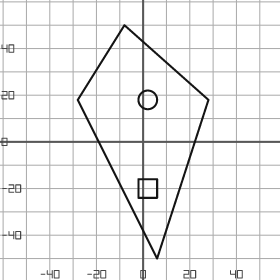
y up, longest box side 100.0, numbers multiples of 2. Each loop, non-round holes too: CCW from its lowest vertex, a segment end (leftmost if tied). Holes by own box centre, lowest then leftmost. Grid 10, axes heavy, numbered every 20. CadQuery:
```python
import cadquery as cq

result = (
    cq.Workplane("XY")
    .moveTo(6.0, -50.0)
    .lineTo(28.0, 18.0)
    .lineTo(-8.0, 50.0)
    .lineTo(-28.0, 18.0)
    .close()
    .moveTo(-2.0, -24.0)
    .lineTo(6.0, -24.0)
    .lineTo(6.0, -16.0)
    .lineTo(-2.0, -16.0)
    .close()
    .moveTo(2.0, 18.0)
    .circle(4.0)
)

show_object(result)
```